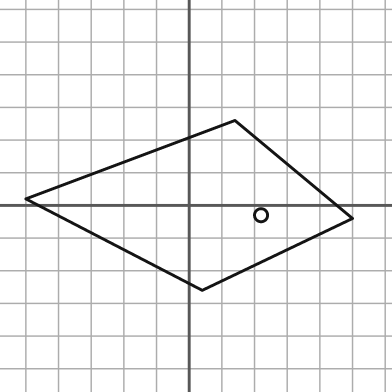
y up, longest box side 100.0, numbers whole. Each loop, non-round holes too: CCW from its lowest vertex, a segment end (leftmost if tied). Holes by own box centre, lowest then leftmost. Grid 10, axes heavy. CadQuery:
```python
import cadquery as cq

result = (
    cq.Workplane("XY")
    .moveTo(4.0, -26.0)
    .lineTo(50.0, -4.0)
    .lineTo(14.0, 26.0)
    .lineTo(-50.0, 2.0)
    .close()
    .moveTo(22.0, -3.0)
    .circle(2.0)
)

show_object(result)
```